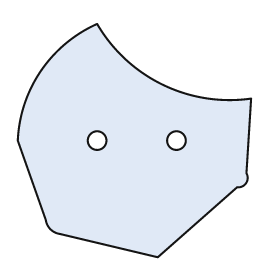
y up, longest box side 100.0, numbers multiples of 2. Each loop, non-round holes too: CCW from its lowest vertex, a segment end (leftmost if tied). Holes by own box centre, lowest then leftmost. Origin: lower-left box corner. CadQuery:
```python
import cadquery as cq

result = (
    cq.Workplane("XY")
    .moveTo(60.0, 0.0)
    .lineTo(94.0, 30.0)
    .threePointArc((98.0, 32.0), (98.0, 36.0))
    .lineTo(100.0, 68.0)
    .threePointArc((62.0, 74.0), (34.0, 100.0))
    .threePointArc((10.0, 80.0), (0.0, 50.0))
    .lineTo(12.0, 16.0)
    .threePointArc((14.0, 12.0), (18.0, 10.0))
    .close()
    .moveTo(34.0, 50.0)
    .circle(4.0)
    .moveTo(68.0, 50.0)
    .circle(4.0)
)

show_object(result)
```